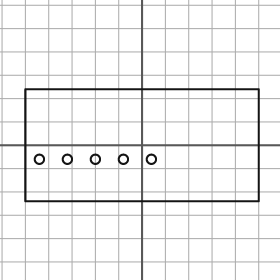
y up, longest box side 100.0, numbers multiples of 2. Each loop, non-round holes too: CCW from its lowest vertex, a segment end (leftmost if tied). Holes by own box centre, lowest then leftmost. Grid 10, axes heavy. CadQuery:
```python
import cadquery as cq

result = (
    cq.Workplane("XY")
    .moveTo(-50.0, -24.0)
    .lineTo(50.0, -24.0)
    .lineTo(50.0, 24.0)
    .lineTo(-50.0, 24.0)
    .close()
    .moveTo(-44.0, -6.0)
    .circle(2.0)
    .moveTo(-32.0, -6.0)
    .circle(2.0)
    .moveTo(-20.0, -6.0)
    .circle(2.0)
    .moveTo(-8.0, -6.0)
    .circle(2.0)
    .moveTo(4.0, -6.0)
    .circle(2.0)
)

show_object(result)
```